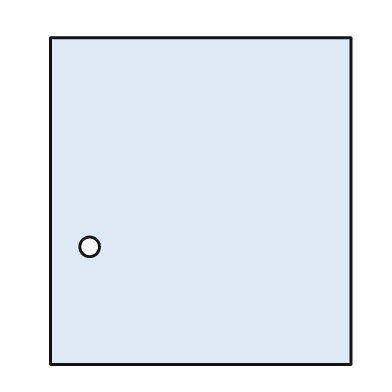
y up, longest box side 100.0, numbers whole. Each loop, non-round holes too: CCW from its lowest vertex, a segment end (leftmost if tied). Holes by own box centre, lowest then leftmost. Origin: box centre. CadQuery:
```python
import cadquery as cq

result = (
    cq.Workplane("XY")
    .moveTo(-46.0, -50.0)
    .lineTo(46.0, -50.0)
    .lineTo(46.0, 50.0)
    .lineTo(-46.0, 50.0)
    .close()
    .moveTo(-34.0, -14.0)
    .circle(3.0)
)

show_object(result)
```